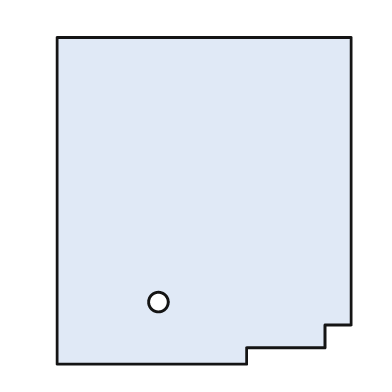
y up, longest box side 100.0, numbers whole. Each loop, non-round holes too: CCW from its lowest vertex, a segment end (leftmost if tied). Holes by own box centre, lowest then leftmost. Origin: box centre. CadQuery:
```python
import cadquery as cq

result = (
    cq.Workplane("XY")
    .moveTo(-45.0, -50.0)
    .lineTo(13.0, -50.0)
    .lineTo(13.0, -45.0)
    .lineTo(37.0, -45.0)
    .lineTo(37.0, -38.0)
    .lineTo(45.0, -38.0)
    .lineTo(45.0, 50.0)
    .lineTo(-45.0, 50.0)
    .close()
    .moveTo(-14.0, -31.0)
    .circle(3.0)
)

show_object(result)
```